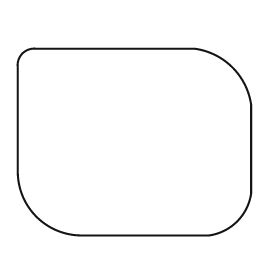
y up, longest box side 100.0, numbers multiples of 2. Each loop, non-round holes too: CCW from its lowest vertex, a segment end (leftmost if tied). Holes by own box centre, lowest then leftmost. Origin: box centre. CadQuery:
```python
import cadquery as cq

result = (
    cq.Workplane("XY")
    .moveTo(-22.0, -40.0)
    .lineTo(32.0, -40.0)
    .threePointArc((44.0, -34.0), (50.0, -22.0))
    .lineTo(50.0, 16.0)
    .threePointArc((42.0, 32.0), (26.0, 40.0))
    .lineTo(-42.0, 40.0)
    .threePointArc((-48.0, 38.0), (-50.0, 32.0))
    .lineTo(-50.0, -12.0)
    .threePointArc((-42.0, -32.0), (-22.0, -40.0))
    .close()
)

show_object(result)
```